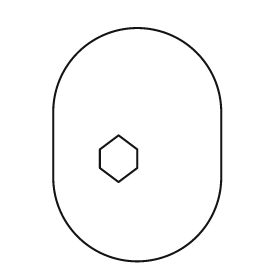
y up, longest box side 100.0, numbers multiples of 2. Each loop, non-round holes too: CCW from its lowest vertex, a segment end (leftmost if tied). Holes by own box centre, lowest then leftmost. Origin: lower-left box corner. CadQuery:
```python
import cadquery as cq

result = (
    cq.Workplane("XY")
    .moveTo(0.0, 36.0)
    .threePointArc((36.0, 0.0), (72.0, 36.0))
    .lineTo(72.0, 64.0)
    .threePointArc((36.0, 100.0), (0.0, 64.0))
    .close()
    .moveTo(28.0, 34.0)
    .lineTo(36.0, 40.0)
    .lineTo(36.0, 48.0)
    .lineTo(28.0, 54.0)
    .lineTo(20.0, 48.0)
    .lineTo(20.0, 40.0)
    .close()
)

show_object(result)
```